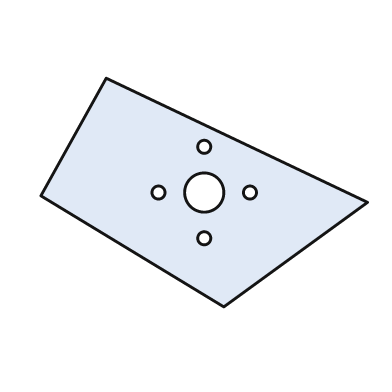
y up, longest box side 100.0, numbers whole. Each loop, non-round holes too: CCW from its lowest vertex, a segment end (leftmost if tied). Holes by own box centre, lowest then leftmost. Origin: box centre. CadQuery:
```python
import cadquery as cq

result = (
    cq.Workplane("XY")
    .moveTo(6.0, -35.0)
    .lineTo(50.0, -3.0)
    .lineTo(-30.0, 35.0)
    .lineTo(-50.0, -1.0)
    .close()
    .moveTo(0.0, -14.0)
    .circle(2.0)
    .moveTo(-14.0, 0.0)
    .circle(2.0)
    .moveTo(0.0, 0.0)
    .circle(6.0)
    .moveTo(14.0, 0.0)
    .circle(2.0)
    .moveTo(0.0, 14.0)
    .circle(2.0)
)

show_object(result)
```